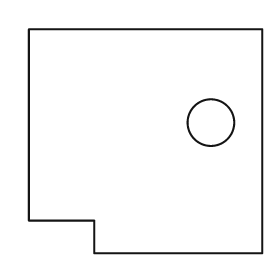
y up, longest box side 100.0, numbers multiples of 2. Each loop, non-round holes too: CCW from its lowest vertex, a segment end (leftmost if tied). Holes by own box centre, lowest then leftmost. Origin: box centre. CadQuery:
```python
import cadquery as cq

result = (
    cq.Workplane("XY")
    .moveTo(-22.0, -48.0)
    .lineTo(50.0, -48.0)
    .lineTo(50.0, 48.0)
    .lineTo(-50.0, 48.0)
    .lineTo(-50.0, -34.0)
    .lineTo(-22.0, -34.0)
    .close()
    .moveTo(28.0, 8.0)
    .circle(10.0)
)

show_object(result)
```